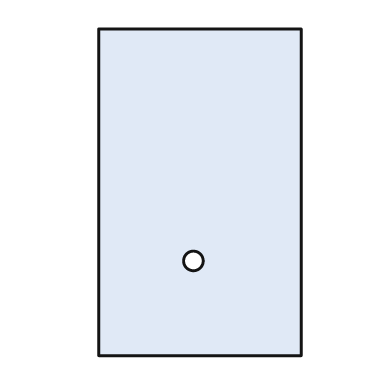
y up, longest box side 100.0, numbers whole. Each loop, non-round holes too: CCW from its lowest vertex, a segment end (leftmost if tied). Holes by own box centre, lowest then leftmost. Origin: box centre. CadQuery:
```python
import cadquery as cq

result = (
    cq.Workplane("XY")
    .moveTo(-31.0, -50.0)
    .lineTo(31.0, -50.0)
    .lineTo(31.0, 50.0)
    .lineTo(-31.0, 50.0)
    .close()
    .moveTo(-2.0, -21.0)
    .circle(3.0)
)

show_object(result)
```